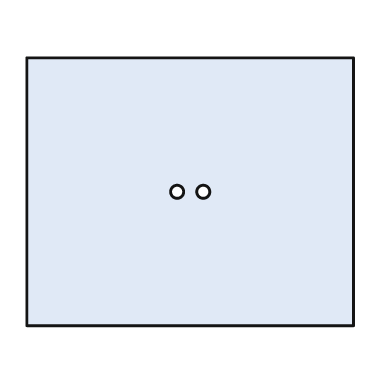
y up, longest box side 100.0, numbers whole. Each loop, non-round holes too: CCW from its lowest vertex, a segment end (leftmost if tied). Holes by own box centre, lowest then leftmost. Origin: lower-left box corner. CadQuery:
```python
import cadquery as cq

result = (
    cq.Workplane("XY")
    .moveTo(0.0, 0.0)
    .lineTo(100.0, 0.0)
    .lineTo(100.0, 82.0)
    .lineTo(0.0, 82.0)
    .close()
    .moveTo(46.0, 41.0)
    .circle(2.0)
    .moveTo(54.0, 41.0)
    .circle(2.0)
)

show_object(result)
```